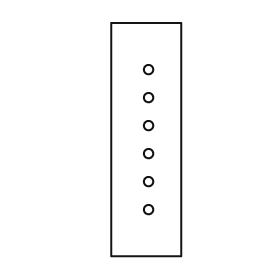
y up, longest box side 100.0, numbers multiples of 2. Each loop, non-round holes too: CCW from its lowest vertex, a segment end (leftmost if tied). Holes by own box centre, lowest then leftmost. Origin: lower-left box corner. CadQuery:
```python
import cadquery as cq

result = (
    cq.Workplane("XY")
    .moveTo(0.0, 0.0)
    .lineTo(30.0, 0.0)
    .lineTo(30.0, 100.0)
    .lineTo(0.0, 100.0)
    .close()
    .moveTo(16.0, 20.0)
    .circle(2.0)
    .moveTo(16.0, 32.0)
    .circle(2.0)
    .moveTo(16.0, 44.0)
    .circle(2.0)
    .moveTo(16.0, 56.0)
    .circle(2.0)
    .moveTo(16.0, 68.0)
    .circle(2.0)
    .moveTo(16.0, 80.0)
    .circle(2.0)
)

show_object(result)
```